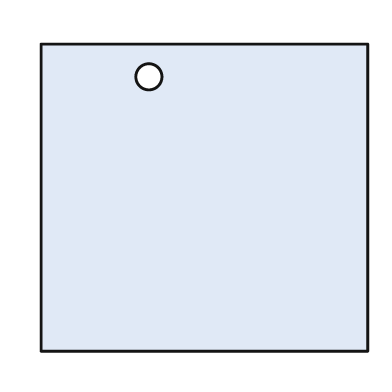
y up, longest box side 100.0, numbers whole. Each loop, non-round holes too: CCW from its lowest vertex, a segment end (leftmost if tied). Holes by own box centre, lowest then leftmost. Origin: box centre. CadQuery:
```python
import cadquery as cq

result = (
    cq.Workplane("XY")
    .moveTo(-50.0, -47.0)
    .lineTo(50.0, -47.0)
    .lineTo(50.0, 47.0)
    .lineTo(-50.0, 47.0)
    .close()
    .moveTo(-17.0, 37.0)
    .circle(4.0)
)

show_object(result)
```